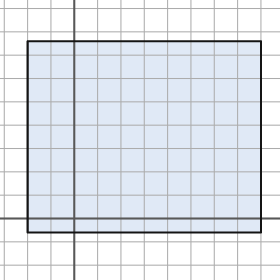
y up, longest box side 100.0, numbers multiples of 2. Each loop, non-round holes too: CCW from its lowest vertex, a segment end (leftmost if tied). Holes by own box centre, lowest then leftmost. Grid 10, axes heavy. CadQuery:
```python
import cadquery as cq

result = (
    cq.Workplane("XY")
    .moveTo(-20.0, -6.0)
    .lineTo(80.0, -6.0)
    .lineTo(80.0, 76.0)
    .lineTo(-20.0, 76.0)
    .close()
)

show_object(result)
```